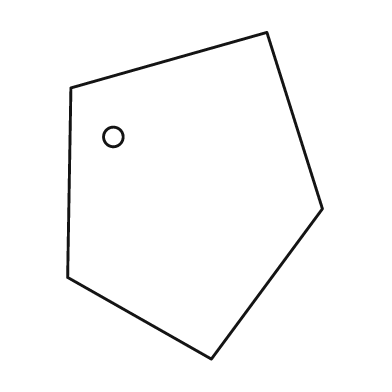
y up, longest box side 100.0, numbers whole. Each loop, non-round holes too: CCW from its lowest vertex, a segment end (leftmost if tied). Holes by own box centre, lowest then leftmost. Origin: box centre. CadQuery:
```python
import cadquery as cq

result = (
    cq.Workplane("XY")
    .moveTo(5.0, -50.0)
    .lineTo(39.0, -4.0)
    .lineTo(22.0, 50.0)
    .lineTo(-38.0, 33.0)
    .lineTo(-39.0, -25.0)
    .close()
    .moveTo(-25.0, 18.0)
    .circle(3.0)
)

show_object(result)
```